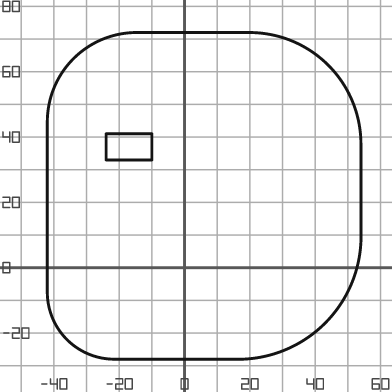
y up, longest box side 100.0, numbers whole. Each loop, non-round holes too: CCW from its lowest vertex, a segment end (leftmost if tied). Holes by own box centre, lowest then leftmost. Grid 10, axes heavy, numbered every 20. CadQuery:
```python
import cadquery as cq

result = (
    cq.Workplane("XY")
    .moveTo(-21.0, -28.0)
    .lineTo(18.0, -28.0)
    .threePointArc((43.0, -17.0), (54.0, 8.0))
    .lineTo(54.0, 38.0)
    .threePointArc((44.0, 62.0), (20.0, 72.0))
    .lineTo(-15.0, 72.0)
    .threePointArc((-34.0, 64.0), (-42.0, 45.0))
    .lineTo(-42.0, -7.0)
    .threePointArc((-36.0, -22.0), (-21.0, -28.0))
    .close()
    .moveTo(-24.0, 33.0)
    .lineTo(-10.0, 33.0)
    .lineTo(-10.0, 41.0)
    .lineTo(-24.0, 41.0)
    .close()
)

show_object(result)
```